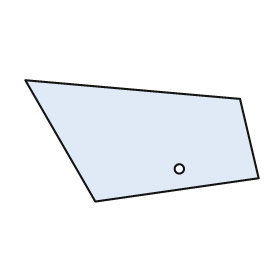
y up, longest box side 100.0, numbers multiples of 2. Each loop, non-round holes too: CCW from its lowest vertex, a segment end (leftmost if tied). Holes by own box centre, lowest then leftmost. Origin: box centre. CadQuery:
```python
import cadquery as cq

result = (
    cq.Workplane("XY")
    .moveTo(-20.0, -26.0)
    .lineTo(50.0, -16.0)
    .lineTo(42.0, 18.0)
    .lineTo(-50.0, 26.0)
    .close()
    .moveTo(16.0, -12.0)
    .circle(2.0)
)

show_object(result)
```